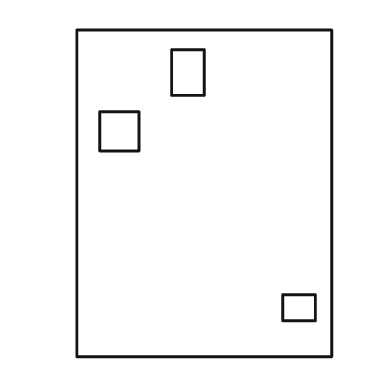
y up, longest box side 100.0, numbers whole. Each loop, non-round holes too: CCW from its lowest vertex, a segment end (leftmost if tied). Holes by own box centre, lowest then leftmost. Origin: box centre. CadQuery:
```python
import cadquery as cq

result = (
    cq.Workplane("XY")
    .moveTo(-39.0, -50.0)
    .lineTo(39.0, -50.0)
    .lineTo(39.0, 50.0)
    .lineTo(-39.0, 50.0)
    .close()
    .moveTo(24.0, -39.0)
    .lineTo(34.0, -39.0)
    .lineTo(34.0, -31.0)
    .lineTo(24.0, -31.0)
    .close()
    .moveTo(-32.0, 13.0)
    .lineTo(-20.0, 13.0)
    .lineTo(-20.0, 25.0)
    .lineTo(-32.0, 25.0)
    .close()
    .moveTo(-10.0, 30.0)
    .lineTo(0.0, 30.0)
    .lineTo(0.0, 44.0)
    .lineTo(-10.0, 44.0)
    .close()
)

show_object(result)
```